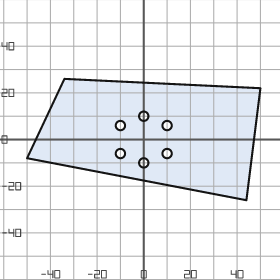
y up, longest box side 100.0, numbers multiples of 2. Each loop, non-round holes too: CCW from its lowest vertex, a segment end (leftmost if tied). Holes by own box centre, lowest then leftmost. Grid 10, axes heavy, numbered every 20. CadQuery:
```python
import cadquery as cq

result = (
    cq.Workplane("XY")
    .moveTo(44.0, -26.0)
    .lineTo(50.0, 22.0)
    .lineTo(-34.0, 26.0)
    .lineTo(-50.0, -8.0)
    .close()
    .moveTo(0.0, -10.0)
    .circle(2.0)
    .moveTo(-10.0, -6.0)
    .circle(2.0)
    .moveTo(10.0, -6.0)
    .circle(2.0)
    .moveTo(-10.0, 6.0)
    .circle(2.0)
    .moveTo(10.0, 6.0)
    .circle(2.0)
    .moveTo(0.0, 10.0)
    .circle(2.0)
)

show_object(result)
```